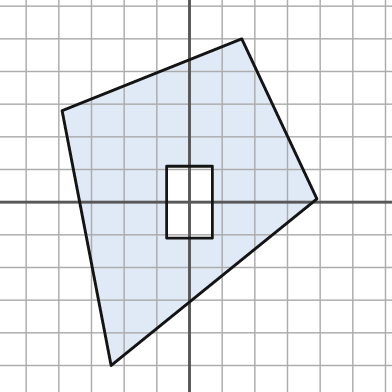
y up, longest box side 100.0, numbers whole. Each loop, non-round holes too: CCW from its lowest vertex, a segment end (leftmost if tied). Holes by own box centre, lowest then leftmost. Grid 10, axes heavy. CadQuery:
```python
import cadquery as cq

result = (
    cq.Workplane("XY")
    .moveTo(-24.0, -50.0)
    .lineTo(39.0, 1.0)
    .lineTo(16.0, 50.0)
    .lineTo(-39.0, 28.0)
    .close()
    .moveTo(-7.0, -11.0)
    .lineTo(7.0, -11.0)
    .lineTo(7.0, 11.0)
    .lineTo(-7.0, 11.0)
    .close()
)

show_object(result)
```